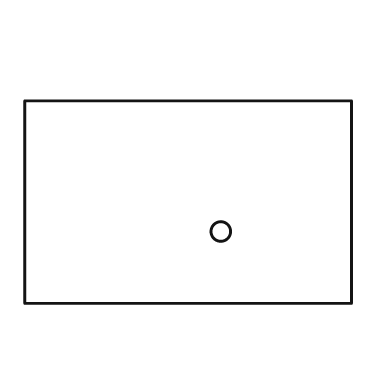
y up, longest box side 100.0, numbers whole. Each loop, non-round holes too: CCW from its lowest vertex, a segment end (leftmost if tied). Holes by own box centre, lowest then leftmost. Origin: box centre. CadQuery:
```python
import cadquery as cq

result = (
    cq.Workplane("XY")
    .moveTo(-50.0, -31.0)
    .lineTo(50.0, -31.0)
    .lineTo(50.0, 31.0)
    .lineTo(-50.0, 31.0)
    .close()
    .moveTo(10.0, -9.0)
    .circle(3.0)
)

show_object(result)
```